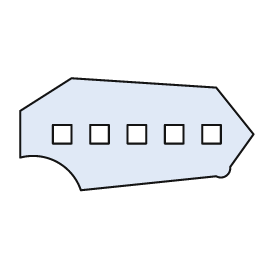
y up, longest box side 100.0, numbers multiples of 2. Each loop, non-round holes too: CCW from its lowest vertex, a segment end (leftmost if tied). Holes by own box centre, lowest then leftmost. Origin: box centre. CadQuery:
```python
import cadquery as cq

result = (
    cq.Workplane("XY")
    .moveTo(-24.0, -24.0)
    .lineTo(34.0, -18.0)
    .threePointArc((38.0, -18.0), (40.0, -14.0))
    .lineTo(50.0, 0.0)
    .lineTo(34.0, 20.0)
    .lineTo(-28.0, 24.0)
    .lineTo(-50.0, 10.0)
    .lineTo(-50.0, -10.0)
    .threePointArc((-34.0, -12.0), (-24.0, -24.0))
    .close()
    .moveTo(-36.0, -4.0)
    .lineTo(-28.0, -4.0)
    .lineTo(-28.0, 4.0)
    .lineTo(-36.0, 4.0)
    .close()
    .moveTo(-20.0, -4.0)
    .lineTo(-12.0, -4.0)
    .lineTo(-12.0, 4.0)
    .lineTo(-20.0, 4.0)
    .close()
    .moveTo(-4.0, -4.0)
    .lineTo(4.0, -4.0)
    .lineTo(4.0, 4.0)
    .lineTo(-4.0, 4.0)
    .close()
    .moveTo(12.0, -4.0)
    .lineTo(20.0, -4.0)
    .lineTo(20.0, 4.0)
    .lineTo(12.0, 4.0)
    .close()
    .moveTo(28.0, -4.0)
    .lineTo(36.0, -4.0)
    .lineTo(36.0, 4.0)
    .lineTo(28.0, 4.0)
    .close()
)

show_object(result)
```